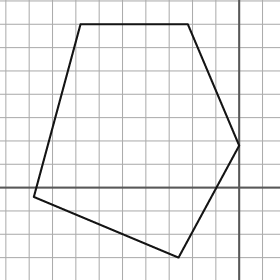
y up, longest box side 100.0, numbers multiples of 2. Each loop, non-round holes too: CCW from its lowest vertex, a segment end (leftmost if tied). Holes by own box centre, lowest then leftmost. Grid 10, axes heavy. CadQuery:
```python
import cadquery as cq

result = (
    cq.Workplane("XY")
    .moveTo(-26.0, -30.0)
    .lineTo(0.0, 18.0)
    .lineTo(-22.0, 70.0)
    .lineTo(-68.0, 70.0)
    .lineTo(-88.0, -4.0)
    .close()
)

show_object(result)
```